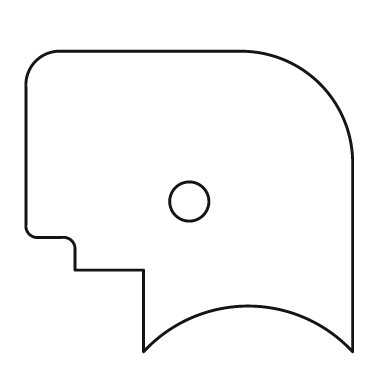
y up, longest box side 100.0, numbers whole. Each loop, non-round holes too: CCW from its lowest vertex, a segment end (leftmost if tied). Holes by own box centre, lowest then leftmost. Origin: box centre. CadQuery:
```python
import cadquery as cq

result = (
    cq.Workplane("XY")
    .moveTo(-14.0, -46.0)
    .threePointArc((18.0, -32.0), (50.0, -46.0))
    .lineTo(50.0, 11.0)
    .threePointArc((40.0, 36.0), (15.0, 46.0))
    .lineTo(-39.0, 46.0)
    .threePointArc((-47.0, 43.0), (-50.0, 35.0))
    .lineTo(-50.0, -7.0)
    .threePointArc((-49.0, -10.0), (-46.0, -11.0))
    .lineTo(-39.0, -11.0)
    .threePointArc((-36.0, -12.0), (-35.0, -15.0))
    .lineTo(-35.0, -21.0)
    .lineTo(-14.0, -21.0)
    .close()
    .moveTo(0.0, 0.0)
    .circle(6.0)
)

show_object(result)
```